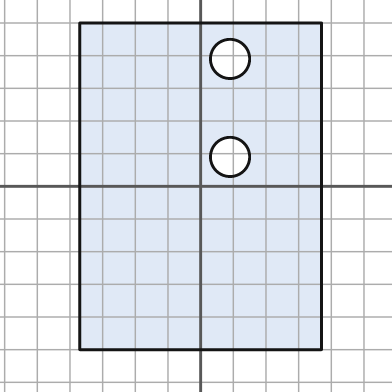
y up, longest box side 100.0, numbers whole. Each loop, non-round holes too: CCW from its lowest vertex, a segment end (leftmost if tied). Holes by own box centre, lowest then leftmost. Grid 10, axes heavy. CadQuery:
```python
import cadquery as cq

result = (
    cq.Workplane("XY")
    .moveTo(-37.0, -50.0)
    .lineTo(37.0, -50.0)
    .lineTo(37.0, 50.0)
    .lineTo(-37.0, 50.0)
    .close()
    .moveTo(9.0, 9.0)
    .circle(6.0)
    .moveTo(9.0, 39.0)
    .circle(6.0)
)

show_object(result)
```